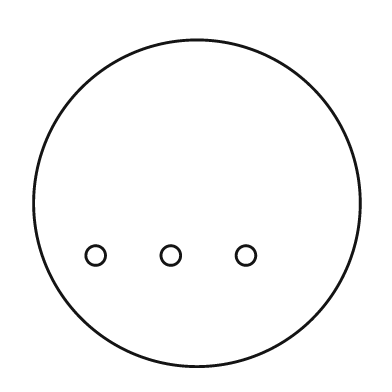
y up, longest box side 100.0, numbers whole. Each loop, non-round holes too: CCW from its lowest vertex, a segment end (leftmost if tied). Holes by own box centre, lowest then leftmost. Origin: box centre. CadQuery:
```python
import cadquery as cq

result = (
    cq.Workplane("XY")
    .moveTo(0.0, 0.0)
    .circle(50.0)
    .moveTo(-31.0, -16.0)
    .circle(3.0)
    .moveTo(-8.0, -16.0)
    .circle(3.0)
    .moveTo(15.0, -16.0)
    .circle(3.0)
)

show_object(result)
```